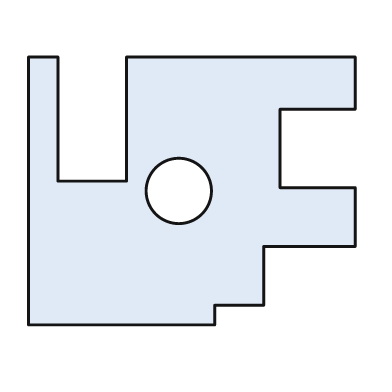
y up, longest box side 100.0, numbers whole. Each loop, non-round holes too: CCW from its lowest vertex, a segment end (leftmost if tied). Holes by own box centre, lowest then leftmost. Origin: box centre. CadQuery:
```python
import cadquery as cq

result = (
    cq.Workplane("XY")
    .moveTo(-50.0, -41.0)
    .lineTo(7.0, -41.0)
    .lineTo(7.0, -35.0)
    .lineTo(22.0, -35.0)
    .lineTo(22.0, -17.0)
    .lineTo(50.0, -17.0)
    .lineTo(50.0, 1.0)
    .lineTo(27.0, 1.0)
    .lineTo(27.0, 25.0)
    .lineTo(50.0, 25.0)
    .lineTo(50.0, 41.0)
    .lineTo(-20.0, 41.0)
    .lineTo(-20.0, 3.0)
    .lineTo(-41.0, 3.0)
    .lineTo(-41.0, 41.0)
    .lineTo(-50.0, 41.0)
    .close()
    .moveTo(-4.0, 0.0)
    .circle(10.0)
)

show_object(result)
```